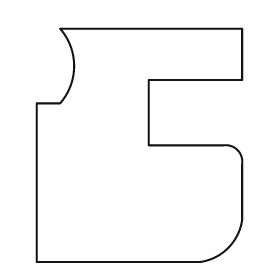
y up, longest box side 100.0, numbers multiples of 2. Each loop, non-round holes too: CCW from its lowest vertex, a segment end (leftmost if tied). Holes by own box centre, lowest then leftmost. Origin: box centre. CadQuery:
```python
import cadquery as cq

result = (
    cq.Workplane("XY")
    .moveTo(-44.0, -50.0)
    .lineTo(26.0, -50.0)
    .threePointArc((38.0, -44.0), (44.0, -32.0))
    .lineTo(44.0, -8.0)
    .threePointArc((42.0, -2.0), (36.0, 0.0))
    .lineTo(4.0, 0.0)
    .lineTo(4.0, 28.0)
    .lineTo(44.0, 28.0)
    .lineTo(44.0, 50.0)
    .lineTo(-34.0, 50.0)
    .threePointArc((-28.0, 34.0), (-34.0, 18.0))
    .lineTo(-44.0, 18.0)
    .close()
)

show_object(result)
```